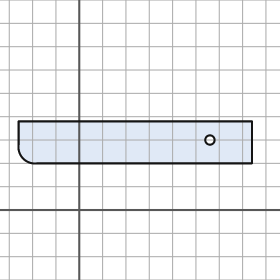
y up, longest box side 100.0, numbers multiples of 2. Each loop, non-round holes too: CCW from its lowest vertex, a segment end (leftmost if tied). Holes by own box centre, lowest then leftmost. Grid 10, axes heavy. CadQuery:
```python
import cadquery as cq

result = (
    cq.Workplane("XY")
    .moveTo(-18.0, 20.0)
    .lineTo(74.0, 20.0)
    .lineTo(74.0, 38.0)
    .lineTo(-26.0, 38.0)
    .lineTo(-26.0, 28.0)
    .threePointArc((-24.0, 22.0), (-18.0, 20.0))
    .close()
    .moveTo(56.0, 30.0)
    .circle(2.0)
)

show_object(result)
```